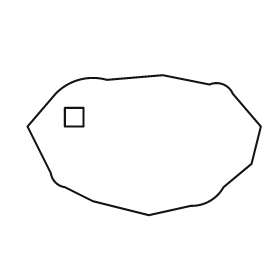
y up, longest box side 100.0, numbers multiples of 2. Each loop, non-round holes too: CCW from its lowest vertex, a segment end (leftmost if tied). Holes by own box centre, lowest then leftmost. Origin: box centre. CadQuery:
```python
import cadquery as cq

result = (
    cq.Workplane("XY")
    .moveTo(2.0, -30.0)
    .lineTo(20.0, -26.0)
    .threePointArc((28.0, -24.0), (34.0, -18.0))
    .lineTo(46.0, -8.0)
    .lineTo(50.0, 8.0)
    .lineTo(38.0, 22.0)
    .threePointArc((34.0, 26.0), (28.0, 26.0))
    .lineTo(8.0, 30.0)
    .lineTo(-16.0, 28.0)
    .threePointArc((-28.0, 28.0), (-38.0, 22.0))
    .lineTo(-50.0, 8.0)
    .lineTo(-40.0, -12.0)
    .threePointArc((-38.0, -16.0), (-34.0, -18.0))
    .lineTo(-22.0, -24.0)
    .close()
    .moveTo(-34.0, 8.0)
    .lineTo(-26.0, 8.0)
    .lineTo(-26.0, 16.0)
    .lineTo(-34.0, 16.0)
    .close()
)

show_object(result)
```